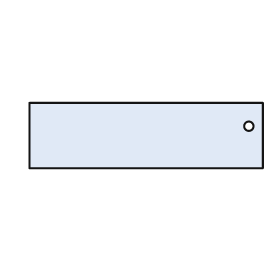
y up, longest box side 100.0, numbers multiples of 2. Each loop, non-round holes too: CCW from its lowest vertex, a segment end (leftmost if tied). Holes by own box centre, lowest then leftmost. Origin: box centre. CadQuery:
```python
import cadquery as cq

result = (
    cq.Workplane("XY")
    .moveTo(-50.0, -14.0)
    .lineTo(50.0, -14.0)
    .lineTo(50.0, 14.0)
    .lineTo(-50.0, 14.0)
    .close()
    .moveTo(44.0, 4.0)
    .circle(2.0)
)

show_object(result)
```